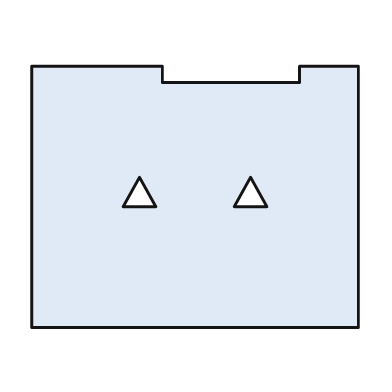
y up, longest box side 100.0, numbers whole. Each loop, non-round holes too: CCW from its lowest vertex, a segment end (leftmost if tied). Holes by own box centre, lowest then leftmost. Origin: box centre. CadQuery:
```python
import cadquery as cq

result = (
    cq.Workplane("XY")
    .moveTo(-50.0, -40.0)
    .lineTo(50.0, -40.0)
    .lineTo(50.0, 40.0)
    .lineTo(32.0, 40.0)
    .lineTo(32.0, 35.0)
    .lineTo(-10.0, 35.0)
    .lineTo(-10.0, 40.0)
    .lineTo(-50.0, 40.0)
    .close()
    .moveTo(-22.0, -3.0)
    .lineTo(-12.0, -3.0)
    .lineTo(-17.0, 6.0)
    .close()
    .moveTo(12.0, -3.0)
    .lineTo(22.0, -3.0)
    .lineTo(17.0, 6.0)
    .close()
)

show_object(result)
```